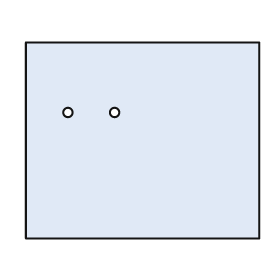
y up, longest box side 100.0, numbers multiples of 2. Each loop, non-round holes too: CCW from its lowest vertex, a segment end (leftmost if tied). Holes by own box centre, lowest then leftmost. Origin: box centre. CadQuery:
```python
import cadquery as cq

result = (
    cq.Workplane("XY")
    .moveTo(-50.0, -42.0)
    .lineTo(50.0, -42.0)
    .lineTo(50.0, 42.0)
    .lineTo(-50.0, 42.0)
    .close()
    .moveTo(-32.0, 12.0)
    .circle(2.0)
    .moveTo(-12.0, 12.0)
    .circle(2.0)
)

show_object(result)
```